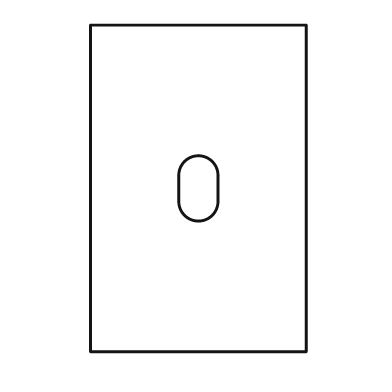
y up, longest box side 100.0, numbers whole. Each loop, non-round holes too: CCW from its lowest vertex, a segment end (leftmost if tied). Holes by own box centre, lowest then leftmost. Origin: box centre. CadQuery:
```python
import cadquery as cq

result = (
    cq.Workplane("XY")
    .moveTo(-33.0, -50.0)
    .lineTo(33.0, -50.0)
    .lineTo(33.0, 50.0)
    .lineTo(-33.0, 50.0)
    .close()
    .moveTo(-6.0, -4.0)
    .threePointArc((0.0, -10.0), (6.0, -4.0))
    .lineTo(6.0, 4.0)
    .threePointArc((0.0, 10.0), (-6.0, 4.0))
    .close()
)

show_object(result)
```